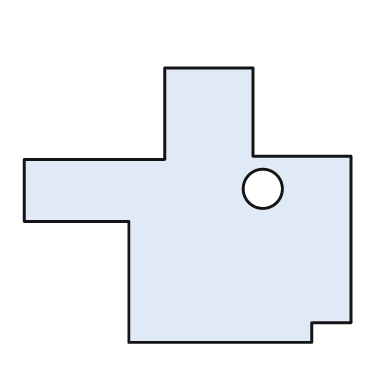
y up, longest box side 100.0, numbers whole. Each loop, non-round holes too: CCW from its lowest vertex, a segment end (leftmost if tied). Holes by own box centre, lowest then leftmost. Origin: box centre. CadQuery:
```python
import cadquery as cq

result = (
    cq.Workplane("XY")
    .moveTo(-18.0, -42.0)
    .lineTo(38.0, -42.0)
    .lineTo(38.0, -36.0)
    .lineTo(50.0, -36.0)
    .lineTo(50.0, 15.0)
    .lineTo(20.0, 15.0)
    .lineTo(20.0, 42.0)
    .lineTo(-7.0, 42.0)
    .lineTo(-7.0, 14.0)
    .lineTo(-50.0, 14.0)
    .lineTo(-50.0, -5.0)
    .lineTo(-18.0, -5.0)
    .close()
    .moveTo(23.0, 5.0)
    .circle(6.0)
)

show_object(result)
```